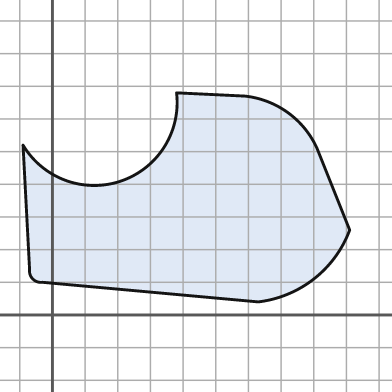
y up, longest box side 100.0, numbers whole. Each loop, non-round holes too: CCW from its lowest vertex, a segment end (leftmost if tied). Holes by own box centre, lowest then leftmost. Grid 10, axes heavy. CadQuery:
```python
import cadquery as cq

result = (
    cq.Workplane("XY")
    .moveTo(63.0, 4.0)
    .threePointArc((80.0, 11.0), (91.0, 26.0))
    .lineTo(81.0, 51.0)
    .threePointArc((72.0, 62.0), (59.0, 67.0))
    .lineTo(38.0, 68.0)
    .threePointArc((21.0, 41.0), (-9.0, 52.0))
    .lineTo(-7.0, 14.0)
    .threePointArc((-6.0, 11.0), (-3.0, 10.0))
    .close()
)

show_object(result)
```